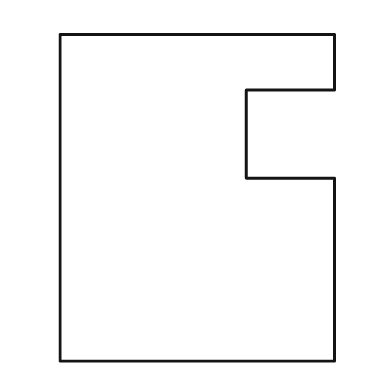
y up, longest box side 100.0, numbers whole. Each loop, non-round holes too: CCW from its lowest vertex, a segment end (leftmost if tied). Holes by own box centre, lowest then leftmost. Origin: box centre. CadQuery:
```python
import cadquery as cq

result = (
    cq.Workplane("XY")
    .moveTo(-42.0, -50.0)
    .lineTo(42.0, -50.0)
    .lineTo(42.0, 6.0)
    .lineTo(15.0, 6.0)
    .lineTo(15.0, 33.0)
    .lineTo(42.0, 33.0)
    .lineTo(42.0, 50.0)
    .lineTo(-42.0, 50.0)
    .close()
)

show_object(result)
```